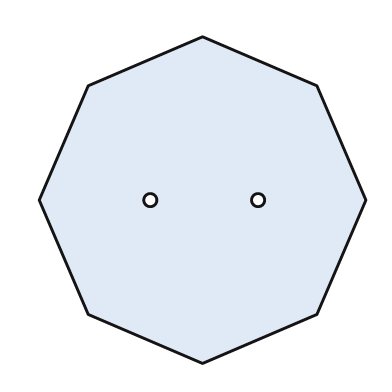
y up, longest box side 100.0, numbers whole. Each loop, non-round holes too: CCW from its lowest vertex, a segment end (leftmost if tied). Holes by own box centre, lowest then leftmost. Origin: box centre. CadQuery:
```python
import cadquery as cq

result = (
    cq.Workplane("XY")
    .moveTo(0.0, -50.0)
    .lineTo(35.0, -35.0)
    .lineTo(50.0, 0.0)
    .lineTo(35.0, 35.0)
    .lineTo(0.0, 50.0)
    .lineTo(-35.0, 35.0)
    .lineTo(-50.0, 0.0)
    .lineTo(-35.0, -35.0)
    .close()
    .moveTo(-16.0, 0.0)
    .circle(2.0)
    .moveTo(17.0, 0.0)
    .circle(2.0)
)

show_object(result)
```